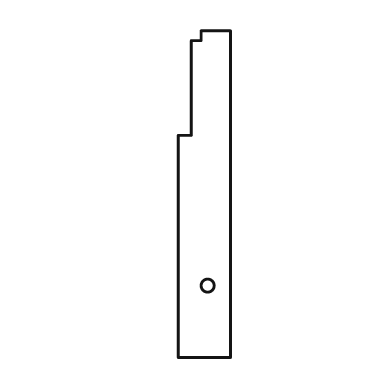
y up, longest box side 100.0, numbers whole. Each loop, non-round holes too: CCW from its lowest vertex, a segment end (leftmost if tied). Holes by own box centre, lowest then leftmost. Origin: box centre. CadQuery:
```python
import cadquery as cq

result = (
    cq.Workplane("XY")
    .moveTo(-8.0, -50.0)
    .lineTo(8.0, -50.0)
    .lineTo(8.0, 50.0)
    .lineTo(-1.0, 50.0)
    .lineTo(-1.0, 47.0)
    .lineTo(-4.0, 47.0)
    .lineTo(-4.0, 18.0)
    .lineTo(-8.0, 18.0)
    .close()
    .moveTo(1.0, -28.0)
    .circle(2.0)
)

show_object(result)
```